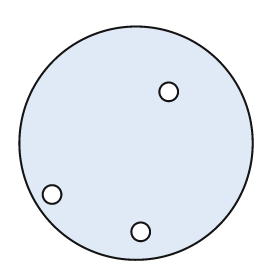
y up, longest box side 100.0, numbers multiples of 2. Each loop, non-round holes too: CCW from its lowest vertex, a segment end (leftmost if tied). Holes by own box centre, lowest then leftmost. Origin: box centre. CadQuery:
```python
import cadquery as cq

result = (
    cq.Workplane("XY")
    .moveTo(0.0, 0.0)
    .circle(50.0)
    .moveTo(2.0, -38.0)
    .circle(4.0)
    .moveTo(-36.0, -22.0)
    .circle(4.0)
    .moveTo(14.0, 22.0)
    .circle(4.0)
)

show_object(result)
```